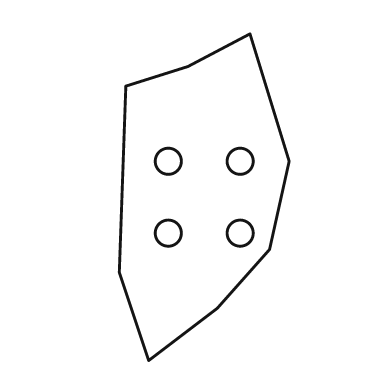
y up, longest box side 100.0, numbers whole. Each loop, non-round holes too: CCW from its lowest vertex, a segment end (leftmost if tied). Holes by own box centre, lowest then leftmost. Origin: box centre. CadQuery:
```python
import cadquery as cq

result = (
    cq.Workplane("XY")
    .moveTo(-17.0, -50.0)
    .lineTo(4.0, -34.0)
    .lineTo(20.0, -16.0)
    .lineTo(26.0, 11.0)
    .lineTo(14.0, 50.0)
    .lineTo(-5.0, 40.0)
    .lineTo(-24.0, 34.0)
    .lineTo(-26.0, -23.0)
    .close()
    .moveTo(-11.0, -11.0)
    .circle(4.0)
    .moveTo(11.0, -11.0)
    .circle(4.0)
    .moveTo(-11.0, 11.0)
    .circle(4.0)
    .moveTo(11.0, 11.0)
    .circle(4.0)
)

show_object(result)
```